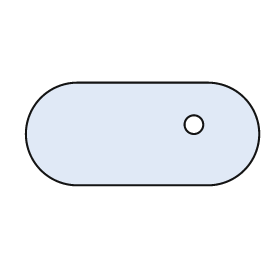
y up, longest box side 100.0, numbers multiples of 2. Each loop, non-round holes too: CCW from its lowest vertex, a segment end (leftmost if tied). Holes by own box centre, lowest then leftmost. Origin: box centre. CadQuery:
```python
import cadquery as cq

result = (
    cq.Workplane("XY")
    .moveTo(-28.0, -22.0)
    .lineTo(28.0, -22.0)
    .threePointArc((50.0, 0.0), (28.0, 22.0))
    .lineTo(-28.0, 22.0)
    .threePointArc((-50.0, 0.0), (-28.0, -22.0))
    .close()
    .moveTo(22.0, 4.0)
    .circle(4.0)
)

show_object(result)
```